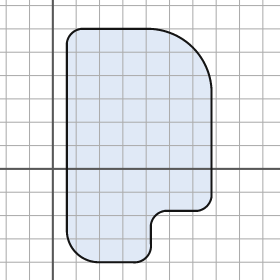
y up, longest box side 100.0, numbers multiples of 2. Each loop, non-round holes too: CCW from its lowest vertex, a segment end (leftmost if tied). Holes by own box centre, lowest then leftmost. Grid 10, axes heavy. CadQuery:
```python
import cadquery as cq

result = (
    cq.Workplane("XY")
    .moveTo(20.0, -40.0)
    .lineTo(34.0, -40.0)
    .threePointArc((40.0, -38.0), (42.0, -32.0))
    .lineTo(42.0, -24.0)
    .threePointArc((44.0, -20.0), (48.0, -18.0))
    .lineTo(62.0, -18.0)
    .threePointArc((66.0, -16.0), (68.0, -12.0))
    .lineTo(68.0, 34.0)
    .threePointArc((60.0, 52.0), (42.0, 60.0))
    .lineTo(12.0, 60.0)
    .threePointArc((8.0, 58.0), (6.0, 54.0))
    .lineTo(6.0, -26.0)
    .threePointArc((10.0, -36.0), (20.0, -40.0))
    .close()
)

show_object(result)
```